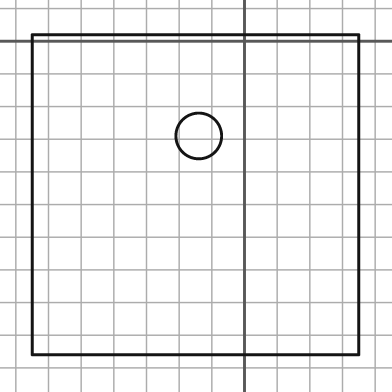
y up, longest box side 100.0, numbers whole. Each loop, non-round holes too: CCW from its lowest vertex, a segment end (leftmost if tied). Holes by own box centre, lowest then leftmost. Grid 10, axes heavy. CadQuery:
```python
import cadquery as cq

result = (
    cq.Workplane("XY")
    .moveTo(-65.0, -96.0)
    .lineTo(35.0, -96.0)
    .lineTo(35.0, 2.0)
    .lineTo(-65.0, 2.0)
    .close()
    .moveTo(-14.0, -29.0)
    .circle(7.0)
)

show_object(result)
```